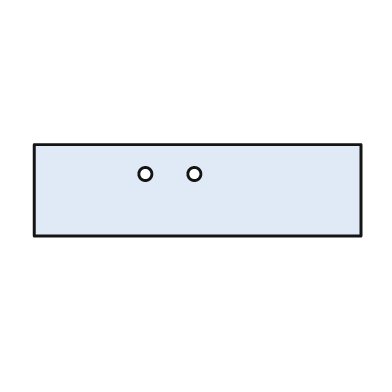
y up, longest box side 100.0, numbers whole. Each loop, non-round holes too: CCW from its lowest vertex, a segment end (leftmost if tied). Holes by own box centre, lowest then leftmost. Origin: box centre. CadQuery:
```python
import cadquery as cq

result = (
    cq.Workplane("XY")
    .moveTo(-50.0, -14.0)
    .lineTo(50.0, -14.0)
    .lineTo(50.0, 14.0)
    .lineTo(-50.0, 14.0)
    .close()
    .moveTo(-16.0, 5.0)
    .circle(2.0)
    .moveTo(-1.0, 5.0)
    .circle(2.0)
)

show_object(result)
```